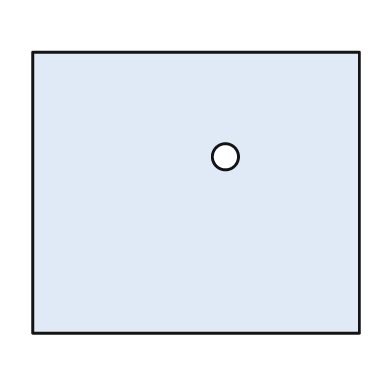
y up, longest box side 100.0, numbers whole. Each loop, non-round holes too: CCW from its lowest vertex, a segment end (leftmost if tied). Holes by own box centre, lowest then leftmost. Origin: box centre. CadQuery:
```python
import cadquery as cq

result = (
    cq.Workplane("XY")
    .moveTo(-50.0, -43.0)
    .lineTo(50.0, -43.0)
    .lineTo(50.0, 43.0)
    .lineTo(-50.0, 43.0)
    .close()
    .moveTo(9.0, 11.0)
    .circle(4.0)
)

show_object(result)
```